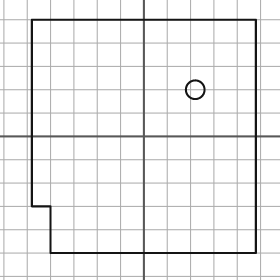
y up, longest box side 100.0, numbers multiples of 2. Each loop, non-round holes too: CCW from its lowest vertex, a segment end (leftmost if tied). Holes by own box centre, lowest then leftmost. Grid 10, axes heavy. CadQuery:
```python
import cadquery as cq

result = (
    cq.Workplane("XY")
    .moveTo(-40.0, -50.0)
    .lineTo(48.0, -50.0)
    .lineTo(48.0, 50.0)
    .lineTo(-48.0, 50.0)
    .lineTo(-48.0, -30.0)
    .lineTo(-40.0, -30.0)
    .close()
    .moveTo(22.0, 20.0)
    .circle(4.0)
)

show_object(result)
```